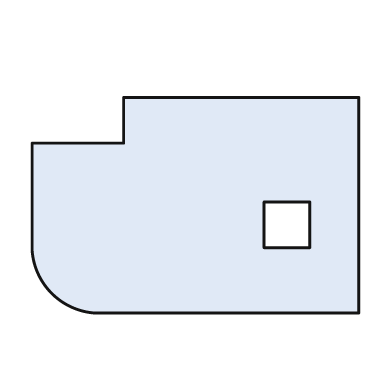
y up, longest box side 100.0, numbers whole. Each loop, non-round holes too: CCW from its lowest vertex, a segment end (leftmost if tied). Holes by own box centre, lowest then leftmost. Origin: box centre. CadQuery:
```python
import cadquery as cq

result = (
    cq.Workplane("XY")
    .moveTo(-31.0, -33.0)
    .lineTo(50.0, -33.0)
    .lineTo(50.0, 33.0)
    .lineTo(-22.0, 33.0)
    .lineTo(-22.0, 19.0)
    .lineTo(-50.0, 19.0)
    .lineTo(-50.0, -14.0)
    .threePointArc((-44.0, -27.0), (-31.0, -33.0))
    .close()
    .moveTo(21.0, -13.0)
    .lineTo(35.0, -13.0)
    .lineTo(35.0, 1.0)
    .lineTo(21.0, 1.0)
    .close()
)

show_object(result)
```